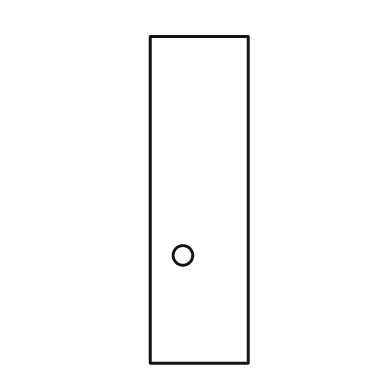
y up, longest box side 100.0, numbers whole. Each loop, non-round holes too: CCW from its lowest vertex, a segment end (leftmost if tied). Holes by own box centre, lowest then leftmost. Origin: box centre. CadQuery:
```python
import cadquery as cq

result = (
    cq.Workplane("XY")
    .moveTo(-15.0, -50.0)
    .lineTo(15.0, -50.0)
    .lineTo(15.0, 50.0)
    .lineTo(-15.0, 50.0)
    .close()
    .moveTo(-5.0, -17.0)
    .circle(3.0)
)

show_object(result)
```